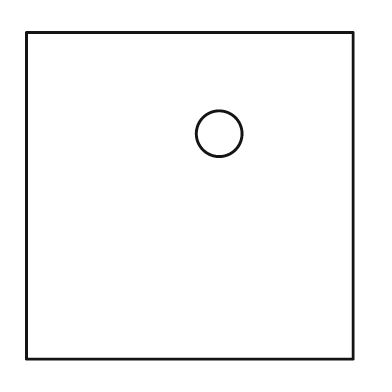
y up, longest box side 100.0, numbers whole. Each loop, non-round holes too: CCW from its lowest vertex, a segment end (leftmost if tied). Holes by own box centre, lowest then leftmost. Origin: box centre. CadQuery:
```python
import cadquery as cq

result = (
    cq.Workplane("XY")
    .moveTo(-50.0, -50.0)
    .lineTo(50.0, -50.0)
    .lineTo(50.0, 50.0)
    .lineTo(-50.0, 50.0)
    .close()
    .moveTo(9.0, 19.0)
    .circle(7.0)
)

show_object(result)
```